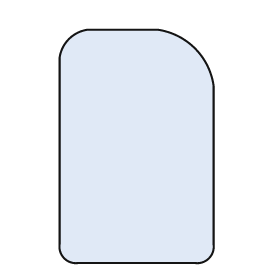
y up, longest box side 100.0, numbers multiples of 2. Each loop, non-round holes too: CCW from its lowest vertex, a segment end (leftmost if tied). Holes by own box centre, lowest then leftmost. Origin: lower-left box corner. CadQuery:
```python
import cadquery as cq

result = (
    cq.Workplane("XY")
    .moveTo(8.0, 0.0)
    .lineTo(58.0, 0.0)
    .threePointArc((64.0, 2.0), (66.0, 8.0))
    .lineTo(66.0, 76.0)
    .threePointArc((58.0, 92.0), (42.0, 100.0))
    .lineTo(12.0, 100.0)
    .threePointArc((4.0, 96.0), (0.0, 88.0))
    .lineTo(0.0, 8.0)
    .threePointArc((2.0, 2.0), (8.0, 0.0))
    .close()
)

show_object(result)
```